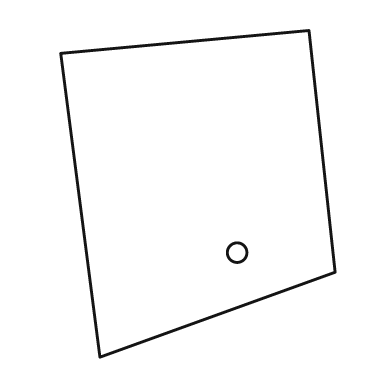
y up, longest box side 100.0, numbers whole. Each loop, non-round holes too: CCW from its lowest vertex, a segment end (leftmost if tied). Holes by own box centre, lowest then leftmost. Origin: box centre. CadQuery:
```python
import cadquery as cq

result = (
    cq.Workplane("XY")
    .moveTo(-30.0, -50.0)
    .lineTo(42.0, -24.0)
    .lineTo(34.0, 50.0)
    .lineTo(-42.0, 43.0)
    .close()
    .moveTo(12.0, -18.0)
    .circle(3.0)
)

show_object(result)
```